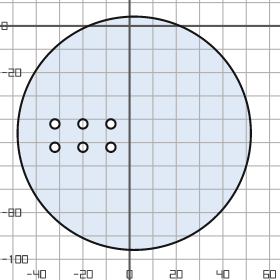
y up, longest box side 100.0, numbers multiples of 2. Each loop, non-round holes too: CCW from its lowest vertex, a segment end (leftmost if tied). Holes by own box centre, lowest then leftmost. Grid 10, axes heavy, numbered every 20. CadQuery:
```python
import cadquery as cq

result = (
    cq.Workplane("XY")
    .moveTo(2.0, -46.0)
    .circle(50.0)
    .moveTo(-32.0, -52.0)
    .circle(2.0)
    .moveTo(-20.0, -52.0)
    .circle(2.0)
    .moveTo(-8.0, -52.0)
    .circle(2.0)
    .moveTo(-32.0, -42.0)
    .circle(2.0)
    .moveTo(-20.0, -42.0)
    .circle(2.0)
    .moveTo(-8.0, -42.0)
    .circle(2.0)
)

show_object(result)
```